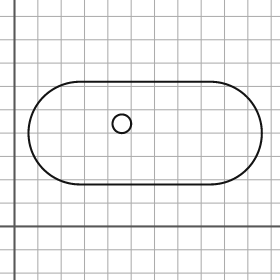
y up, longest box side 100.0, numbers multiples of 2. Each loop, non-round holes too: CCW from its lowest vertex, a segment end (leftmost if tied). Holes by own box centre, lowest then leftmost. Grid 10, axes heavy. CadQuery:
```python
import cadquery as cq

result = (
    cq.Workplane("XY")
    .moveTo(28.0, 18.0)
    .lineTo(84.0, 18.0)
    .threePointArc((106.0, 40.0), (84.0, 62.0))
    .lineTo(28.0, 62.0)
    .threePointArc((6.0, 40.0), (28.0, 18.0))
    .close()
    .moveTo(46.0, 44.0)
    .circle(4.0)
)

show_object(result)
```